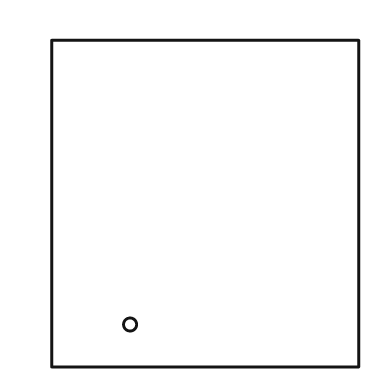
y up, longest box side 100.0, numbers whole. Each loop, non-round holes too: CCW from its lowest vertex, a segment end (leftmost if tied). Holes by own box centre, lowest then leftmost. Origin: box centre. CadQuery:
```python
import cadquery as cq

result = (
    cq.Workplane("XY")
    .moveTo(-47.0, -50.0)
    .lineTo(47.0, -50.0)
    .lineTo(47.0, 50.0)
    .lineTo(-47.0, 50.0)
    .close()
    .moveTo(-23.0, -37.0)
    .circle(2.0)
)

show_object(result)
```